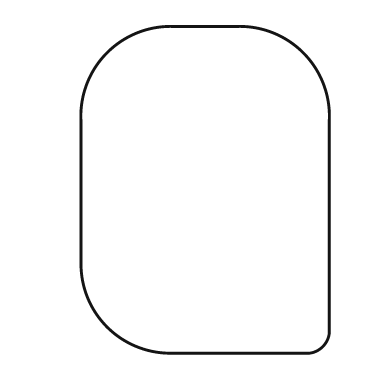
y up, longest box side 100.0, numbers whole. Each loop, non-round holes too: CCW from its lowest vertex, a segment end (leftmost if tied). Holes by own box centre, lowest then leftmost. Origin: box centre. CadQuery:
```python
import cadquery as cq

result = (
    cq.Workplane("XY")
    .moveTo(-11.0, -50.0)
    .lineTo(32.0, -50.0)
    .threePointArc((36.0, -48.0), (38.0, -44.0))
    .lineTo(38.0, 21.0)
    .threePointArc((30.0, 42.0), (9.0, 50.0))
    .lineTo(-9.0, 50.0)
    .threePointArc((-30.0, 42.0), (-38.0, 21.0))
    .lineTo(-38.0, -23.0)
    .threePointArc((-30.0, -42.0), (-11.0, -50.0))
    .close()
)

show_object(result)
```